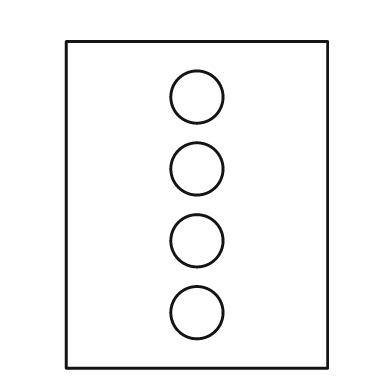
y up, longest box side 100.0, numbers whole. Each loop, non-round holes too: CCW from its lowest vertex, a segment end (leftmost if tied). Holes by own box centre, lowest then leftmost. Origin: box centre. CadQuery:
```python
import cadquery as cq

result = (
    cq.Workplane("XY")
    .moveTo(-40.0, -50.0)
    .lineTo(40.0, -50.0)
    .lineTo(40.0, 50.0)
    .lineTo(-40.0, 50.0)
    .close()
    .moveTo(0.0, -33.0)
    .circle(8.0)
    .moveTo(0.0, -11.0)
    .circle(8.0)
    .moveTo(0.0, 11.0)
    .circle(8.0)
    .moveTo(0.0, 33.0)
    .circle(8.0)
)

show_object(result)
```